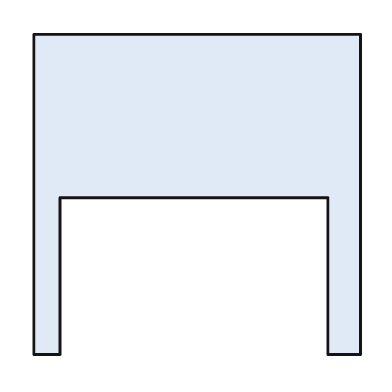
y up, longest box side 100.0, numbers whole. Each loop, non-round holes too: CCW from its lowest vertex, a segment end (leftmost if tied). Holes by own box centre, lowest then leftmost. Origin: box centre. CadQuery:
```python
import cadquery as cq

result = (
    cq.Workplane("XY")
    .moveTo(-50.0, -49.0)
    .lineTo(-42.0, -49.0)
    .lineTo(-42.0, -1.0)
    .lineTo(40.0, -1.0)
    .lineTo(40.0, -49.0)
    .lineTo(50.0, -49.0)
    .lineTo(50.0, 49.0)
    .lineTo(-50.0, 49.0)
    .close()
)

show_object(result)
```